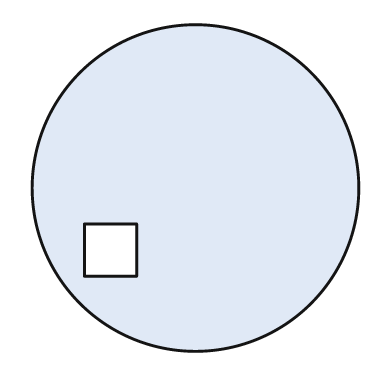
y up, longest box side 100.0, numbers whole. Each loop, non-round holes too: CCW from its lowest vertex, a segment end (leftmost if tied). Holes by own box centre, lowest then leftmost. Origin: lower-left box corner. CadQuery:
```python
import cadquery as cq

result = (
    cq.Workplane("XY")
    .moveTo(50.0, 50.0)
    .circle(50.0)
    .moveTo(16.0, 23.0)
    .lineTo(32.0, 23.0)
    .lineTo(32.0, 39.0)
    .lineTo(16.0, 39.0)
    .close()
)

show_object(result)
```